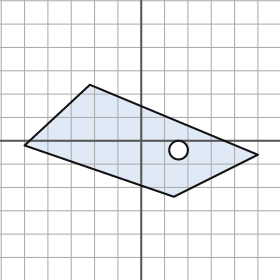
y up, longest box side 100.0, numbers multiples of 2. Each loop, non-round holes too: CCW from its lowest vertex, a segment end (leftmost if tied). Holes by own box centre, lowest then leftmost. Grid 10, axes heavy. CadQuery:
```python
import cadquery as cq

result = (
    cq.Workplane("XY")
    .moveTo(14.0, -24.0)
    .lineTo(50.0, -6.0)
    .lineTo(-22.0, 24.0)
    .lineTo(-50.0, -2.0)
    .close()
    .moveTo(16.0, -4.0)
    .circle(4.0)
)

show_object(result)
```